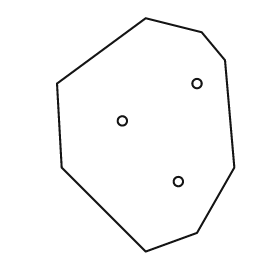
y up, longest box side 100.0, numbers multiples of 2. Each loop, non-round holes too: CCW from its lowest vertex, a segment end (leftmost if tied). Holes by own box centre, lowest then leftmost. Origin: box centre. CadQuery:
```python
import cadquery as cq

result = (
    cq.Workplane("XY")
    .moveTo(0.0, -50.0)
    .lineTo(22.0, -42.0)
    .lineTo(38.0, -14.0)
    .lineTo(34.0, 32.0)
    .lineTo(24.0, 44.0)
    .lineTo(0.0, 50.0)
    .lineTo(-38.0, 22.0)
    .lineTo(-36.0, -14.0)
    .close()
    .moveTo(14.0, -20.0)
    .circle(2.0)
    .moveTo(-10.0, 6.0)
    .circle(2.0)
    .moveTo(22.0, 22.0)
    .circle(2.0)
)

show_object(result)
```